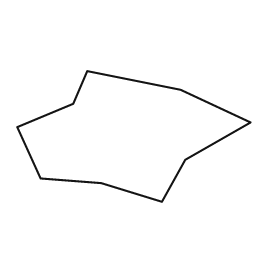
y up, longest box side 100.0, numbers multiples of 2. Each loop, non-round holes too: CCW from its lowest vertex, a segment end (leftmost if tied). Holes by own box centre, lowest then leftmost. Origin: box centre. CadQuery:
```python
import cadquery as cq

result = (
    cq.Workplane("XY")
    .moveTo(12.0, -28.0)
    .lineTo(22.0, -10.0)
    .lineTo(50.0, 6.0)
    .lineTo(20.0, 20.0)
    .lineTo(-20.0, 28.0)
    .lineTo(-26.0, 14.0)
    .lineTo(-50.0, 4.0)
    .lineTo(-40.0, -18.0)
    .lineTo(-14.0, -20.0)
    .close()
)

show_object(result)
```